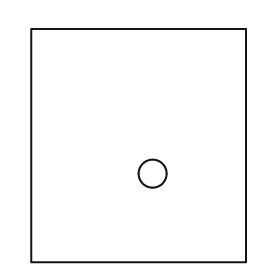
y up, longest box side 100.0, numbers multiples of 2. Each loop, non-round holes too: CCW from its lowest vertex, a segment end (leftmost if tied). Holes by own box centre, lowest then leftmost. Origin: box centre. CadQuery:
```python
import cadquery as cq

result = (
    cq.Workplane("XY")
    .moveTo(-46.0, -50.0)
    .lineTo(46.0, -50.0)
    .lineTo(46.0, 50.0)
    .lineTo(-46.0, 50.0)
    .close()
    .moveTo(6.0, -12.0)
    .circle(6.0)
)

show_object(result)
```